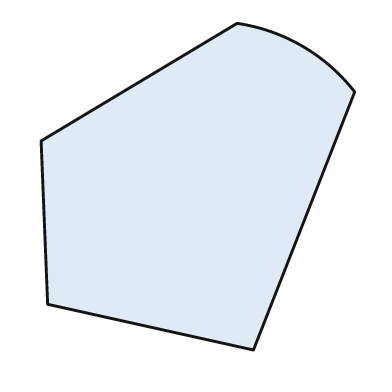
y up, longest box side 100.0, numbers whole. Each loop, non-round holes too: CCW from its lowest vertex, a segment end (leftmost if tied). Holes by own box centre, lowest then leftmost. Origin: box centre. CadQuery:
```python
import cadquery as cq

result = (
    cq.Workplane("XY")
    .moveTo(17.0, -50.0)
    .lineTo(48.0, 29.0)
    .threePointArc((32.0, 43.0), (12.0, 50.0))
    .lineTo(-48.0, 14.0)
    .lineTo(-46.0, -36.0)
    .close()
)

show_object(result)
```